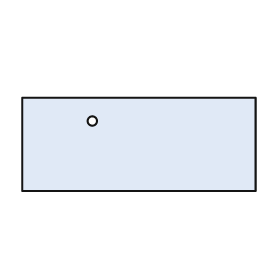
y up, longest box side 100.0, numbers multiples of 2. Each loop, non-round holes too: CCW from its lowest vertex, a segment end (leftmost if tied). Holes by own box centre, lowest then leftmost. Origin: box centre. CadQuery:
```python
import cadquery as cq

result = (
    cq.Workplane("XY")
    .moveTo(-50.0, -20.0)
    .lineTo(50.0, -20.0)
    .lineTo(50.0, 20.0)
    .lineTo(-50.0, 20.0)
    .close()
    .moveTo(-20.0, 10.0)
    .circle(2.0)
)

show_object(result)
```